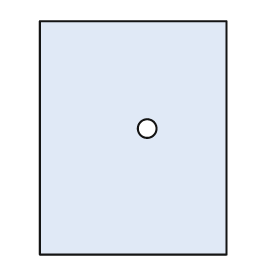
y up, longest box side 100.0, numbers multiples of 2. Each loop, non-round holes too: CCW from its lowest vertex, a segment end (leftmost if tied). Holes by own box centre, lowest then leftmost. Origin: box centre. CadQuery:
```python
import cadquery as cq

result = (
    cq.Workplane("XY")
    .moveTo(-40.0, -50.0)
    .lineTo(40.0, -50.0)
    .lineTo(40.0, 50.0)
    .lineTo(-40.0, 50.0)
    .close()
    .moveTo(6.0, 4.0)
    .circle(4.0)
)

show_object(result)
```